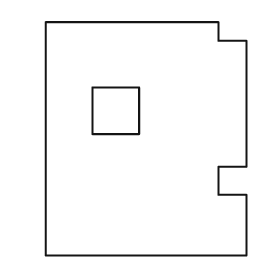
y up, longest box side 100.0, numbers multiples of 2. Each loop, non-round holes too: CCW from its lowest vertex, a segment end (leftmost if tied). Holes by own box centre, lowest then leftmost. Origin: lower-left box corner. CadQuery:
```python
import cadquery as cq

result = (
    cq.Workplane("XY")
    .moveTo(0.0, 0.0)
    .lineTo(86.0, 0.0)
    .lineTo(86.0, 26.0)
    .lineTo(74.0, 26.0)
    .lineTo(74.0, 38.0)
    .lineTo(86.0, 38.0)
    .lineTo(86.0, 92.0)
    .lineTo(74.0, 92.0)
    .lineTo(74.0, 100.0)
    .lineTo(0.0, 100.0)
    .close()
    .moveTo(20.0, 52.0)
    .lineTo(40.0, 52.0)
    .lineTo(40.0, 72.0)
    .lineTo(20.0, 72.0)
    .close()
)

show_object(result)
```